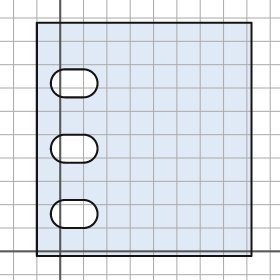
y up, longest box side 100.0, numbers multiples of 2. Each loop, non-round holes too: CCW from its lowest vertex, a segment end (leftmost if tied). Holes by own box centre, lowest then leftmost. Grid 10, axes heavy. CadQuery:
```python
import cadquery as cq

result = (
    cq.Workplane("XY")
    .moveTo(-10.0, -2.0)
    .lineTo(82.0, -2.0)
    .lineTo(82.0, 98.0)
    .lineTo(-10.0, 98.0)
    .close()
    .moveTo(2.0, 10.0)
    .lineTo(10.0, 10.0)
    .threePointArc((16.0, 16.0), (10.0, 22.0))
    .lineTo(2.0, 22.0)
    .threePointArc((-4.0, 16.0), (2.0, 10.0))
    .close()
    .moveTo(2.0, 38.0)
    .lineTo(10.0, 38.0)
    .threePointArc((16.0, 44.0), (10.0, 50.0))
    .lineTo(2.0, 50.0)
    .threePointArc((-4.0, 44.0), (2.0, 38.0))
    .close()
    .moveTo(2.0, 66.0)
    .lineTo(10.0, 66.0)
    .threePointArc((16.0, 72.0), (10.0, 78.0))
    .lineTo(2.0, 78.0)
    .threePointArc((-4.0, 72.0), (2.0, 66.0))
    .close()
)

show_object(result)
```